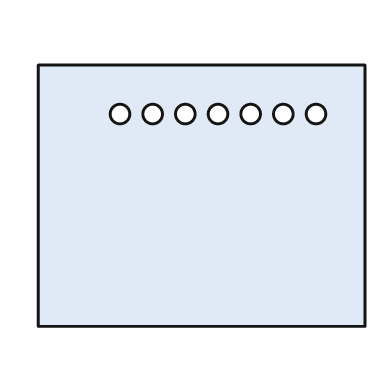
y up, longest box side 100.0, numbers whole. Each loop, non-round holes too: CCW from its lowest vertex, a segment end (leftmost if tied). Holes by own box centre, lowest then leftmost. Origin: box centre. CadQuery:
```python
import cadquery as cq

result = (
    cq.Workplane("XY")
    .moveTo(-50.0, -40.0)
    .lineTo(50.0, -40.0)
    .lineTo(50.0, 40.0)
    .lineTo(-50.0, 40.0)
    .close()
    .moveTo(-25.0, 25.0)
    .circle(3.0)
    .moveTo(-15.0, 25.0)
    .circle(3.0)
    .moveTo(-5.0, 25.0)
    .circle(3.0)
    .moveTo(5.0, 25.0)
    .circle(3.0)
    .moveTo(15.0, 25.0)
    .circle(3.0)
    .moveTo(25.0, 25.0)
    .circle(3.0)
    .moveTo(35.0, 25.0)
    .circle(3.0)
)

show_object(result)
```